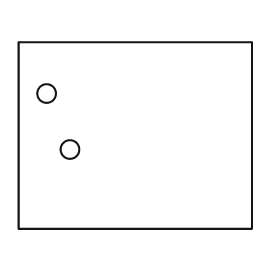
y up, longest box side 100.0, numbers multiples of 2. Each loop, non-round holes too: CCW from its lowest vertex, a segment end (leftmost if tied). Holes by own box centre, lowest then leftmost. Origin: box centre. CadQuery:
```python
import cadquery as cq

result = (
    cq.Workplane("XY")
    .moveTo(-50.0, -40.0)
    .lineTo(50.0, -40.0)
    .lineTo(50.0, 40.0)
    .lineTo(-50.0, 40.0)
    .close()
    .moveTo(-28.0, -6.0)
    .circle(4.0)
    .moveTo(-38.0, 18.0)
    .circle(4.0)
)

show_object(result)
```